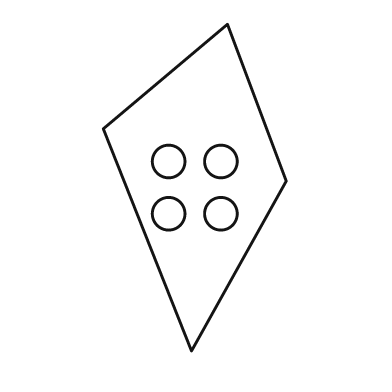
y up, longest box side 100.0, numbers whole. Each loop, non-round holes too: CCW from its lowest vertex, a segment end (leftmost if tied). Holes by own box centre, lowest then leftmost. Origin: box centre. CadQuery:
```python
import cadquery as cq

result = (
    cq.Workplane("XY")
    .moveTo(-1.0, -50.0)
    .lineTo(28.0, 2.0)
    .lineTo(10.0, 50.0)
    .lineTo(-28.0, 18.0)
    .close()
    .moveTo(-8.0, -8.0)
    .circle(5.0)
    .moveTo(8.0, -8.0)
    .circle(5.0)
    .moveTo(-8.0, 8.0)
    .circle(5.0)
    .moveTo(8.0, 8.0)
    .circle(5.0)
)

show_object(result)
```